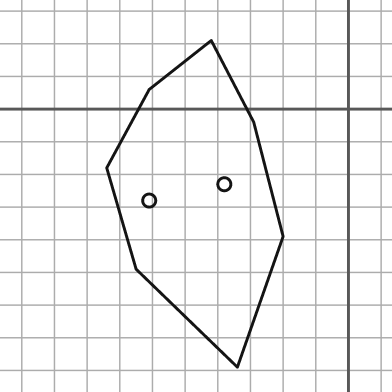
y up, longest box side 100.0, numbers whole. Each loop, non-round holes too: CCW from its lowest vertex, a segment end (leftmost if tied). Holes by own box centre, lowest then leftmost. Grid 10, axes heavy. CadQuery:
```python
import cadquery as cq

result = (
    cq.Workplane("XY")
    .moveTo(-34.0, -79.0)
    .lineTo(-20.0, -39.0)
    .lineTo(-29.0, -4.0)
    .lineTo(-42.0, 21.0)
    .lineTo(-61.0, 6.0)
    .lineTo(-74.0, -18.0)
    .lineTo(-65.0, -49.0)
    .close()
    .moveTo(-61.0, -28.0)
    .circle(2.0)
    .moveTo(-38.0, -23.0)
    .circle(2.0)
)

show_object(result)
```